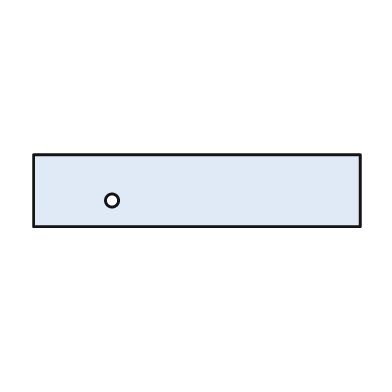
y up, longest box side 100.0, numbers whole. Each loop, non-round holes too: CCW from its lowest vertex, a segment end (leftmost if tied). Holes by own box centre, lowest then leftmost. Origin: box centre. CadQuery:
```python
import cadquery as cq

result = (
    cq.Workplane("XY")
    .moveTo(-50.0, -11.0)
    .lineTo(50.0, -11.0)
    .lineTo(50.0, 11.0)
    .lineTo(-50.0, 11.0)
    .close()
    .moveTo(-26.0, -3.0)
    .circle(2.0)
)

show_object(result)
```